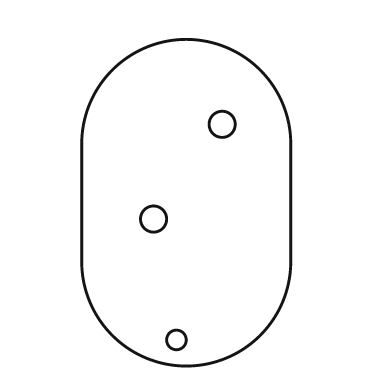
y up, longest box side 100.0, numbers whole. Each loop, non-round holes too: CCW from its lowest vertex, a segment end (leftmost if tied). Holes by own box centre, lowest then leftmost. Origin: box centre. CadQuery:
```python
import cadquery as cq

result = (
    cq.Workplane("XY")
    .moveTo(-32.0, -18.0)
    .threePointArc((0.0, -50.0), (32.0, -18.0))
    .lineTo(32.0, 18.0)
    .threePointArc((0.0, 50.0), (-32.0, 18.0))
    .close()
    .moveTo(-3.0, -42.0)
    .circle(3.0)
    .moveTo(-10.0, -5.0)
    .circle(4.0)
    .moveTo(11.0, 24.0)
    .circle(4.0)
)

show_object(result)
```